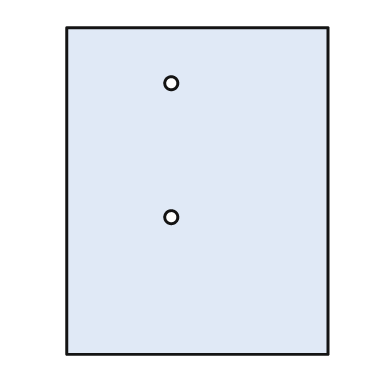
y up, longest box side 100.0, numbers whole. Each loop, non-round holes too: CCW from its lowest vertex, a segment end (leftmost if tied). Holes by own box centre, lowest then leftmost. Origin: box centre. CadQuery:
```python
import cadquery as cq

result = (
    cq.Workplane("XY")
    .moveTo(-40.0, -50.0)
    .lineTo(40.0, -50.0)
    .lineTo(40.0, 50.0)
    .lineTo(-40.0, 50.0)
    .close()
    .moveTo(-8.0, -8.0)
    .circle(2.0)
    .moveTo(-8.0, 33.0)
    .circle(2.0)
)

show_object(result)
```